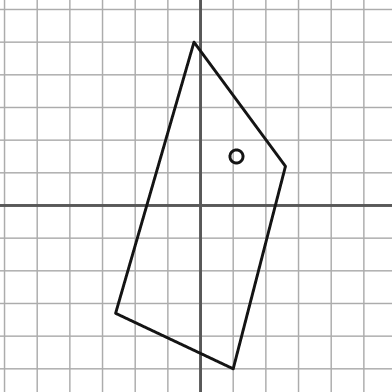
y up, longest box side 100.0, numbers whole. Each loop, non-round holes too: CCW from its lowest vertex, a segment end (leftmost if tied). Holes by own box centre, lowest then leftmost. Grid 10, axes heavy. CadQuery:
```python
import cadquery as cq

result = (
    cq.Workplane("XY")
    .moveTo(10.0, -50.0)
    .lineTo(26.0, 12.0)
    .lineTo(-2.0, 50.0)
    .lineTo(-26.0, -33.0)
    .close()
    .moveTo(11.0, 15.0)
    .circle(2.0)
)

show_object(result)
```